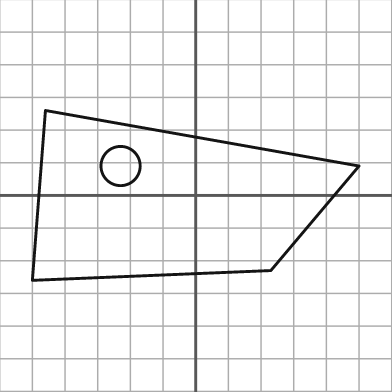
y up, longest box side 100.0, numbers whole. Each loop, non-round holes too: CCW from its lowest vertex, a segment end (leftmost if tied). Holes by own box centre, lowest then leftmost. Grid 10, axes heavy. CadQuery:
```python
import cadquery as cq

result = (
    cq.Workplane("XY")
    .moveTo(-50.0, -26.0)
    .lineTo(23.0, -23.0)
    .lineTo(50.0, 9.0)
    .lineTo(-46.0, 26.0)
    .close()
    .moveTo(-23.0, 9.0)
    .circle(6.0)
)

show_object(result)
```